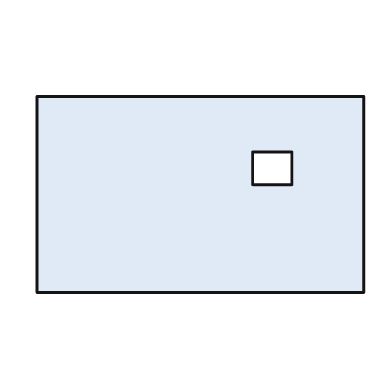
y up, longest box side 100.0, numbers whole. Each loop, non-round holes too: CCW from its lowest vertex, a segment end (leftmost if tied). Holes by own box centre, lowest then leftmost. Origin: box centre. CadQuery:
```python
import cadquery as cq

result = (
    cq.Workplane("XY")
    .moveTo(-50.0, -30.0)
    .lineTo(50.0, -30.0)
    .lineTo(50.0, 30.0)
    .lineTo(-50.0, 30.0)
    .close()
    .moveTo(16.0, 3.0)
    .lineTo(28.0, 3.0)
    .lineTo(28.0, 13.0)
    .lineTo(16.0, 13.0)
    .close()
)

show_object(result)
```